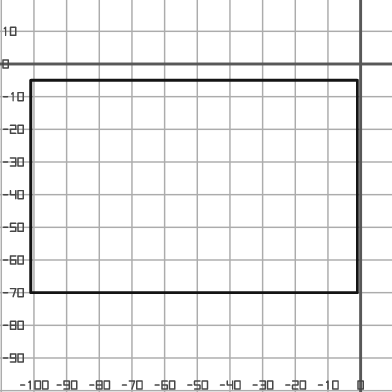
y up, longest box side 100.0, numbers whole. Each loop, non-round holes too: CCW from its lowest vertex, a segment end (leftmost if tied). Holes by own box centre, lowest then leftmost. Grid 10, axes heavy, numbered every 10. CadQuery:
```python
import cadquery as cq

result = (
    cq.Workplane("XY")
    .moveTo(-101.0, -70.0)
    .lineTo(-1.0, -70.0)
    .lineTo(-1.0, -5.0)
    .lineTo(-101.0, -5.0)
    .close()
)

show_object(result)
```